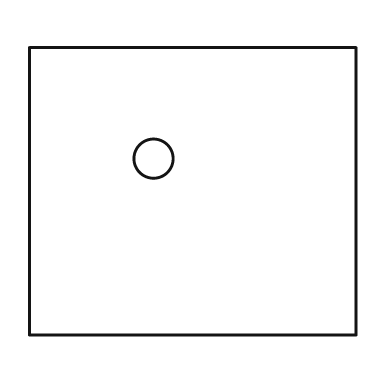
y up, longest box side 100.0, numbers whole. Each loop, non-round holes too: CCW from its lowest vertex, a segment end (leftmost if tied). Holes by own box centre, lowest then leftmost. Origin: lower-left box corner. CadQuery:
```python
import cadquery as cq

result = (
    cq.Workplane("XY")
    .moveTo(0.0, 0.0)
    .lineTo(100.0, 0.0)
    .lineTo(100.0, 88.0)
    .lineTo(0.0, 88.0)
    .close()
    .moveTo(38.0, 54.0)
    .circle(6.0)
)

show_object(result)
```